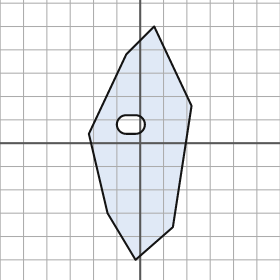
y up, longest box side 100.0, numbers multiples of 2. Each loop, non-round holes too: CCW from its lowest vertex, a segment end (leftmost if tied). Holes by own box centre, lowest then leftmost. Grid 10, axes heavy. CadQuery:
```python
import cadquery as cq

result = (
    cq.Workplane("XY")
    .moveTo(-2.0, -50.0)
    .lineTo(14.0, -36.0)
    .lineTo(22.0, 16.0)
    .lineTo(6.0, 50.0)
    .lineTo(-6.0, 38.0)
    .lineTo(-22.0, 4.0)
    .lineTo(-14.0, -30.0)
    .close()
    .moveTo(-6.0, 4.0)
    .lineTo(-2.0, 4.0)
    .threePointArc((2.0, 8.0), (-2.0, 12.0))
    .lineTo(-6.0, 12.0)
    .threePointArc((-10.0, 8.0), (-6.0, 4.0))
    .close()
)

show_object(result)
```